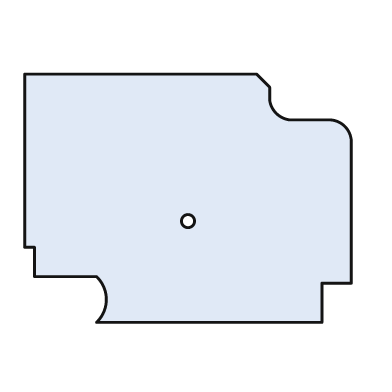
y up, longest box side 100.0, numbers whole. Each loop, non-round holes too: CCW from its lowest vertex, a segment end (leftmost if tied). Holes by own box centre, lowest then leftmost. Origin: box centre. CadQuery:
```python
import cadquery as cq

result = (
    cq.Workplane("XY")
    .moveTo(-28.0, -38.0)
    .lineTo(41.0, -38.0)
    .lineTo(41.0, -26.0)
    .lineTo(50.0, -26.0)
    .lineTo(50.0, 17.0)
    .threePointArc((48.0, 22.0), (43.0, 24.0))
    .lineTo(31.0, 24.0)
    .threePointArc((27.0, 26.0), (25.0, 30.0))
    .lineTo(25.0, 34.0)
    .lineTo(21.0, 38.0)
    .lineTo(-50.0, 38.0)
    .lineTo(-50.0, -15.0)
    .lineTo(-47.0, -15.0)
    .lineTo(-47.0, -24.0)
    .lineTo(-28.0, -24.0)
    .threePointArc((-25.0, -31.0), (-28.0, -38.0))
    .close()
    .moveTo(0.0, -7.0)
    .circle(2.0)
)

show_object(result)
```